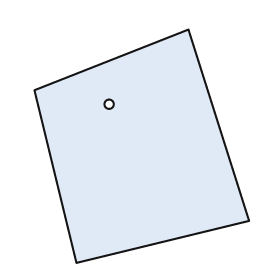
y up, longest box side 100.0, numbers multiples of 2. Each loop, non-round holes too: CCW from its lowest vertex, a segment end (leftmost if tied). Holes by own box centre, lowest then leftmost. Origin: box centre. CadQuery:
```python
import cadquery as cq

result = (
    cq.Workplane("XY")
    .moveTo(-28.0, -50.0)
    .lineTo(46.0, -32.0)
    .lineTo(20.0, 50.0)
    .lineTo(-46.0, 24.0)
    .close()
    .moveTo(-14.0, 18.0)
    .circle(2.0)
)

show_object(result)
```